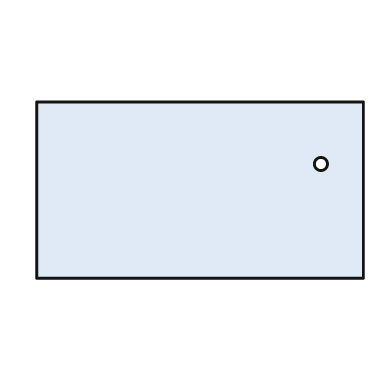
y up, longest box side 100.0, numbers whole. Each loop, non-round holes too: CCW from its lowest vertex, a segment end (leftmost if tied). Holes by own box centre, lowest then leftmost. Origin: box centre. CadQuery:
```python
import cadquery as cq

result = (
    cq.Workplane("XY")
    .moveTo(-50.0, -27.0)
    .lineTo(50.0, -27.0)
    .lineTo(50.0, 27.0)
    .lineTo(-50.0, 27.0)
    .close()
    .moveTo(37.0, 8.0)
    .circle(2.0)
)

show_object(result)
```